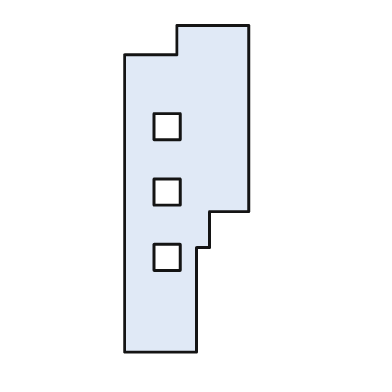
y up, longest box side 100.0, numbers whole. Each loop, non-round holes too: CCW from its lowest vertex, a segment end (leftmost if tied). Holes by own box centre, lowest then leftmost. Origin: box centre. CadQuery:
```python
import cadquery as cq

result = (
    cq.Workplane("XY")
    .moveTo(-19.0, -50.0)
    .lineTo(3.0, -50.0)
    .lineTo(3.0, -18.0)
    .lineTo(7.0, -18.0)
    .lineTo(7.0, -7.0)
    .lineTo(19.0, -7.0)
    .lineTo(19.0, 50.0)
    .lineTo(-3.0, 50.0)
    .lineTo(-3.0, 41.0)
    .lineTo(-19.0, 41.0)
    .close()
    .moveTo(-10.0, -25.0)
    .lineTo(-2.0, -25.0)
    .lineTo(-2.0, -17.0)
    .lineTo(-10.0, -17.0)
    .close()
    .moveTo(-10.0, -5.0)
    .lineTo(-2.0, -5.0)
    .lineTo(-2.0, 3.0)
    .lineTo(-10.0, 3.0)
    .close()
    .moveTo(-10.0, 15.0)
    .lineTo(-2.0, 15.0)
    .lineTo(-2.0, 23.0)
    .lineTo(-10.0, 23.0)
    .close()
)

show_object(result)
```